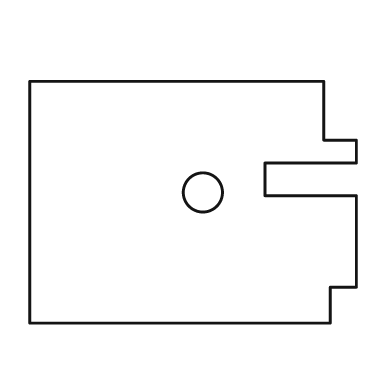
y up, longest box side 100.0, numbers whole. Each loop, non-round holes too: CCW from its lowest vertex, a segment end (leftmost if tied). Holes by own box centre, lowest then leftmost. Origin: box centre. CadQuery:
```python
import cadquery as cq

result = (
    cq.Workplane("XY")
    .moveTo(-50.0, -37.0)
    .lineTo(42.0, -37.0)
    .lineTo(42.0, -26.0)
    .lineTo(50.0, -26.0)
    .lineTo(50.0, 2.0)
    .lineTo(22.0, 2.0)
    .lineTo(22.0, 12.0)
    .lineTo(50.0, 12.0)
    .lineTo(50.0, 19.0)
    .lineTo(40.0, 19.0)
    .lineTo(40.0, 37.0)
    .lineTo(-50.0, 37.0)
    .close()
    .moveTo(3.0, 3.0)
    .circle(6.0)
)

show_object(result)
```